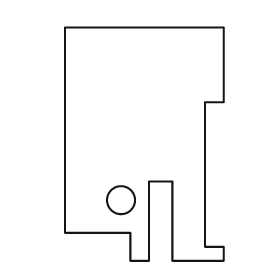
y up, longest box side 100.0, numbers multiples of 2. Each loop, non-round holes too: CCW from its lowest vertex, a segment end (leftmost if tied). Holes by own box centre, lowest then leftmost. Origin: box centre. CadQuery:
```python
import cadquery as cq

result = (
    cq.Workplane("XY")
    .moveTo(-6.0, -50.0)
    .lineTo(2.0, -50.0)
    .lineTo(2.0, -16.0)
    .lineTo(12.0, -16.0)
    .lineTo(12.0, -50.0)
    .lineTo(34.0, -50.0)
    .lineTo(34.0, -44.0)
    .lineTo(26.0, -44.0)
    .lineTo(26.0, 18.0)
    .lineTo(34.0, 18.0)
    .lineTo(34.0, 50.0)
    .lineTo(-34.0, 50.0)
    .lineTo(-34.0, -38.0)
    .lineTo(-6.0, -38.0)
    .close()
    .moveTo(-10.0, -24.0)
    .circle(6.0)
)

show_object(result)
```